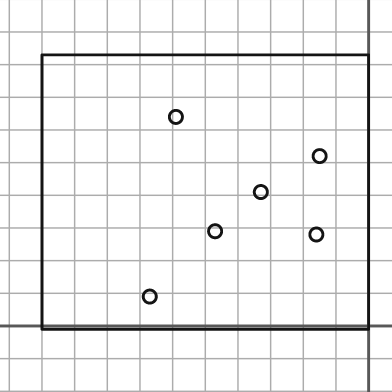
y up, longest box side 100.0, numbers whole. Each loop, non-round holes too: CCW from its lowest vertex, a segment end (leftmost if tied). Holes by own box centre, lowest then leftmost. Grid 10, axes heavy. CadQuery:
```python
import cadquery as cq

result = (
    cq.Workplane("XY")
    .moveTo(-100.0, -1.0)
    .lineTo(0.0, -1.0)
    .lineTo(0.0, 83.0)
    .lineTo(-100.0, 83.0)
    .close()
    .moveTo(-67.0, 9.0)
    .circle(2.0)
    .moveTo(-16.0, 28.0)
    .circle(2.0)
    .moveTo(-47.0, 29.0)
    .circle(2.0)
    .moveTo(-33.0, 41.0)
    .circle(2.0)
    .moveTo(-15.0, 52.0)
    .circle(2.0)
    .moveTo(-59.0, 64.0)
    .circle(2.0)
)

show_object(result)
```